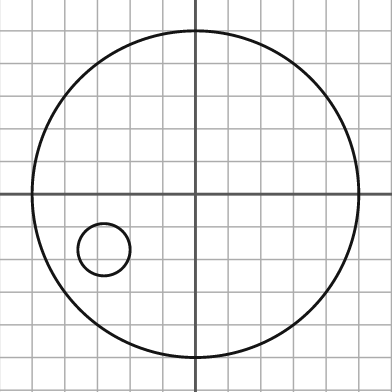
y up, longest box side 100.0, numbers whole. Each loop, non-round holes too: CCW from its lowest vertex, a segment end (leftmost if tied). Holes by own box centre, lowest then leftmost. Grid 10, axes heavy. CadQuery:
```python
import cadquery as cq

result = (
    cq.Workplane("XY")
    .moveTo(0.0, 0.0)
    .circle(50.0)
    .moveTo(-28.0, -17.0)
    .circle(8.0)
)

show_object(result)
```